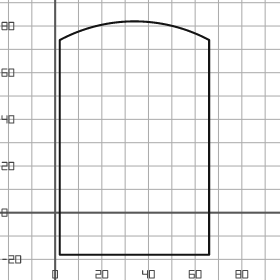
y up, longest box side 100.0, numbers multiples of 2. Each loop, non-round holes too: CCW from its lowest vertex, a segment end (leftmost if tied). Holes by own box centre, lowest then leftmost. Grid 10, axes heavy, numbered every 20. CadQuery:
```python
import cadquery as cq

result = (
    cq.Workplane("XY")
    .moveTo(2.0, -18.0)
    .lineTo(66.0, -18.0)
    .lineTo(66.0, 74.0)
    .threePointArc((34.0, 82.0), (2.0, 74.0))
    .close()
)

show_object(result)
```